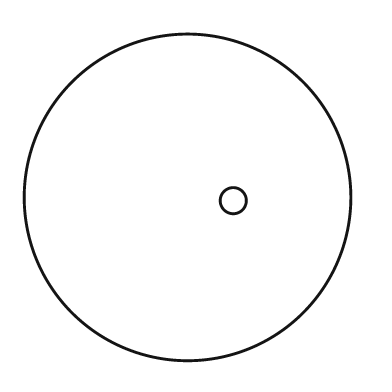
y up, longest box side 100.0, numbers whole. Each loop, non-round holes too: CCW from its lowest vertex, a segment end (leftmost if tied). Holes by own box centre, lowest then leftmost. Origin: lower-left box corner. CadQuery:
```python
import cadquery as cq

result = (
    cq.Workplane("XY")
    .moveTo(50.0, 50.0)
    .circle(50.0)
    .moveTo(64.0, 49.0)
    .circle(4.0)
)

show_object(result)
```